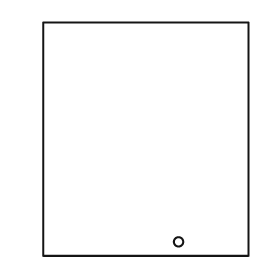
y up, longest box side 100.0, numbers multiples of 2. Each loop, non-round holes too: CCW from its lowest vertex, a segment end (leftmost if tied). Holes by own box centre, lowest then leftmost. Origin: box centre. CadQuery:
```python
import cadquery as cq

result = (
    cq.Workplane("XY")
    .moveTo(-44.0, -50.0)
    .lineTo(44.0, -50.0)
    .lineTo(44.0, 50.0)
    .lineTo(-44.0, 50.0)
    .close()
    .moveTo(14.0, -44.0)
    .circle(2.0)
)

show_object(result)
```